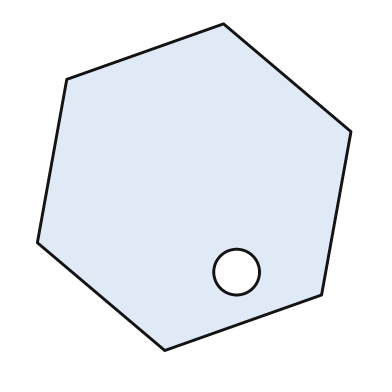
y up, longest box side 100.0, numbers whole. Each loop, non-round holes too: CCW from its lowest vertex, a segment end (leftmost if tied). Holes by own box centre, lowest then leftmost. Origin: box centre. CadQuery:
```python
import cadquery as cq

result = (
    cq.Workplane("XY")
    .moveTo(-9.0, -50.0)
    .lineTo(39.0, -33.0)
    .lineTo(48.0, 17.0)
    .lineTo(9.0, 50.0)
    .lineTo(-39.0, 33.0)
    .lineTo(-48.0, -17.0)
    .close()
    .moveTo(13.0, -26.0)
    .circle(7.0)
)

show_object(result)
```